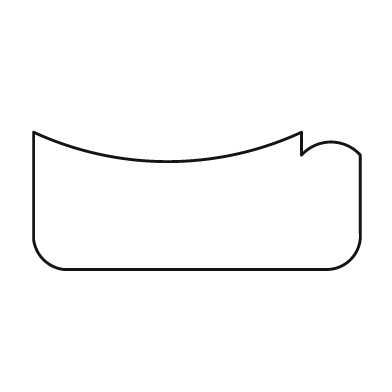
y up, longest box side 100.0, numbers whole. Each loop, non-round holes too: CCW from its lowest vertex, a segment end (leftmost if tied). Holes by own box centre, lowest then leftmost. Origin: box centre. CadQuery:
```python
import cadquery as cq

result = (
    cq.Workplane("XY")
    .moveTo(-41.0, -21.0)
    .lineTo(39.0, -21.0)
    .threePointArc((47.0, -18.0), (50.0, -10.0))
    .lineTo(50.0, 14.0)
    .threePointArc((41.0, 18.0), (32.0, 14.0))
    .lineTo(32.0, 21.0)
    .threePointArc((-9.0, 12.0), (-50.0, 21.0))
    .lineTo(-50.0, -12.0)
    .threePointArc((-47.0, -18.0), (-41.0, -21.0))
    .close()
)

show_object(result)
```